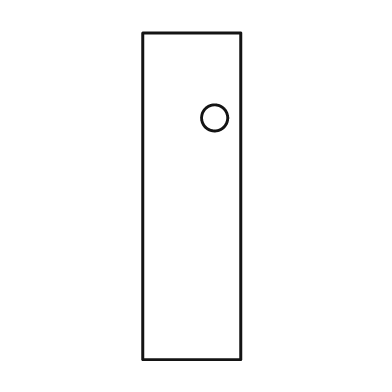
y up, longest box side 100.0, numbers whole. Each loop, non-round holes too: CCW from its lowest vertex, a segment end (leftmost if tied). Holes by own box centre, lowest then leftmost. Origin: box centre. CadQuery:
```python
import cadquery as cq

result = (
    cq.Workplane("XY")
    .moveTo(-15.0, -50.0)
    .lineTo(15.0, -50.0)
    .lineTo(15.0, 50.0)
    .lineTo(-15.0, 50.0)
    .close()
    .moveTo(7.0, 24.0)
    .circle(4.0)
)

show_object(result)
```